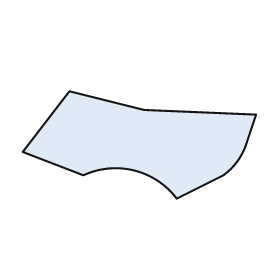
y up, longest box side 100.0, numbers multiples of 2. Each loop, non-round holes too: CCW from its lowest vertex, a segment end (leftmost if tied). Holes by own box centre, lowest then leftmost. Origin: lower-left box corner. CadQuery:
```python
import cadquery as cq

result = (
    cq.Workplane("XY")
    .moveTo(66.0, 0.0)
    .lineTo(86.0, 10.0)
    .threePointArc((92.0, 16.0), (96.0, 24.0))
    .lineTo(100.0, 36.0)
    .lineTo(52.0, 38.0)
    .lineTo(20.0, 46.0)
    .lineTo(0.0, 20.0)
    .lineTo(26.0, 10.0)
    .threePointArc((48.0, 12.0), (66.0, 0.0))
    .close()
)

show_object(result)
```